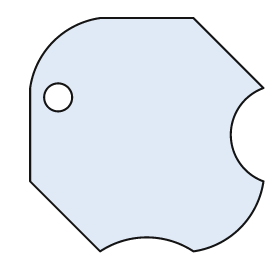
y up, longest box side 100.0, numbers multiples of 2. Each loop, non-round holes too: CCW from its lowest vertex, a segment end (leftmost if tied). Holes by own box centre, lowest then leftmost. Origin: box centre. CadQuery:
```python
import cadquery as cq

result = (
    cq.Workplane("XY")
    .moveTo(-20.0, -50.0)
    .threePointArc((0.0, -44.0), (20.0, -50.0))
    .threePointArc((40.0, -40.0), (50.0, -20.0))
    .threePointArc((36.0, 0.0), (50.0, 20.0))
    .lineTo(20.0, 50.0)
    .lineTo(-20.0, 50.0)
    .threePointArc((-40.0, 40.0), (-50.0, 20.0))
    .lineTo(-50.0, -20.0)
    .close()
    .moveTo(-38.0, 16.0)
    .circle(6.0)
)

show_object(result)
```